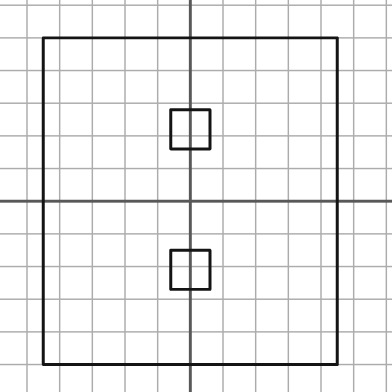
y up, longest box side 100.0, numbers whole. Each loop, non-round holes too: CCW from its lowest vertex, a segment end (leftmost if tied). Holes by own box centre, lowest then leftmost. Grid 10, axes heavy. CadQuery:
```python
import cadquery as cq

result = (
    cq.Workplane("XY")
    .moveTo(-45.0, -50.0)
    .lineTo(45.0, -50.0)
    .lineTo(45.0, 50.0)
    .lineTo(-45.0, 50.0)
    .close()
    .moveTo(-6.0, -27.0)
    .lineTo(6.0, -27.0)
    .lineTo(6.0, -15.0)
    .lineTo(-6.0, -15.0)
    .close()
    .moveTo(-6.0, 16.0)
    .lineTo(6.0, 16.0)
    .lineTo(6.0, 28.0)
    .lineTo(-6.0, 28.0)
    .close()
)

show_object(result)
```